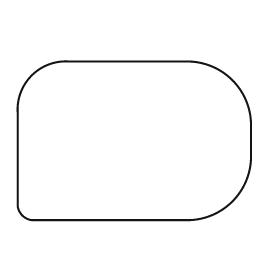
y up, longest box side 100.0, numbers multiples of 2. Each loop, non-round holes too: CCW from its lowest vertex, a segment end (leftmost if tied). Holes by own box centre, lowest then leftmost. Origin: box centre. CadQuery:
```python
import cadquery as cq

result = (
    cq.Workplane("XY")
    .moveTo(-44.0, -34.0)
    .lineTo(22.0, -34.0)
    .threePointArc((42.0, -26.0), (50.0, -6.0))
    .lineTo(50.0, 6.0)
    .threePointArc((42.0, 26.0), (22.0, 34.0))
    .lineTo(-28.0, 34.0)
    .threePointArc((-44.0, 28.0), (-50.0, 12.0))
    .lineTo(-50.0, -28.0)
    .threePointArc((-48.0, -32.0), (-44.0, -34.0))
    .close()
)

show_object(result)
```